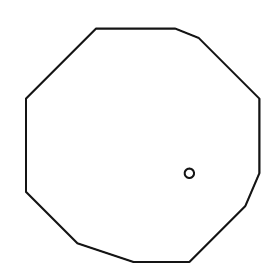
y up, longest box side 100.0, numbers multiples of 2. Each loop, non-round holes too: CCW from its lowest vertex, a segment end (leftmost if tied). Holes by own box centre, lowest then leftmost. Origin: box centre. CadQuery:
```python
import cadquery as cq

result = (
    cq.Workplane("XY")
    .moveTo(-4.0, -50.0)
    .lineTo(20.0, -50.0)
    .lineTo(44.0, -26.0)
    .lineTo(50.0, -12.0)
    .lineTo(50.0, 20.0)
    .lineTo(24.0, 46.0)
    .lineTo(14.0, 50.0)
    .lineTo(-20.0, 50.0)
    .lineTo(-50.0, 20.0)
    .lineTo(-50.0, -20.0)
    .lineTo(-28.0, -42.0)
    .close()
    .moveTo(20.0, -12.0)
    .circle(2.0)
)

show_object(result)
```